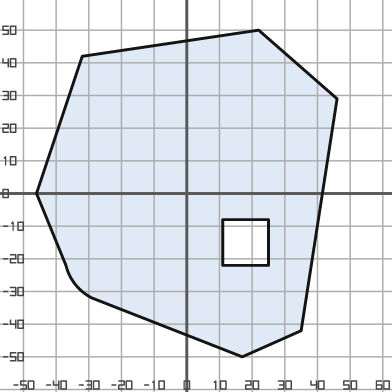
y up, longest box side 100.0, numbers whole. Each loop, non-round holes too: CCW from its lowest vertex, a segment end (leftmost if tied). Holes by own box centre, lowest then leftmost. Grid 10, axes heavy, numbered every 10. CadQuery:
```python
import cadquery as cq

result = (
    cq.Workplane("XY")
    .moveTo(17.0, -50.0)
    .lineTo(35.0, -42.0)
    .lineTo(46.0, 29.0)
    .lineTo(22.0, 50.0)
    .lineTo(-32.0, 42.0)
    .lineTo(-46.0, 0.0)
    .lineTo(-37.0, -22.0)
    .threePointArc((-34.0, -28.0), (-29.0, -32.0))
    .close()
    .moveTo(11.0, -22.0)
    .lineTo(25.0, -22.0)
    .lineTo(25.0, -8.0)
    .lineTo(11.0, -8.0)
    .close()
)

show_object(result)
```